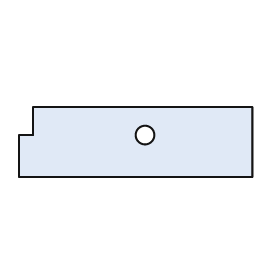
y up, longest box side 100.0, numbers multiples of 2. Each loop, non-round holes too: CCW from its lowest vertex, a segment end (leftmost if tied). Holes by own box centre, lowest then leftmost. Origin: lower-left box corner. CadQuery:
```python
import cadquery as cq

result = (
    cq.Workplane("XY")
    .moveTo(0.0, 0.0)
    .lineTo(100.0, 0.0)
    .lineTo(100.0, 30.0)
    .lineTo(6.0, 30.0)
    .lineTo(6.0, 18.0)
    .lineTo(0.0, 18.0)
    .close()
    .moveTo(54.0, 18.0)
    .circle(4.0)
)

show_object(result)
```